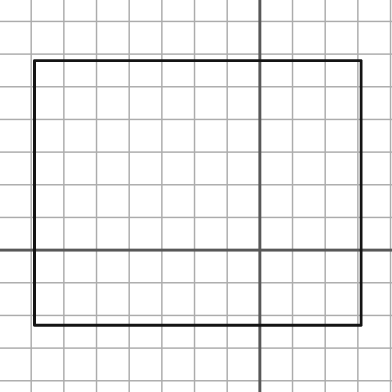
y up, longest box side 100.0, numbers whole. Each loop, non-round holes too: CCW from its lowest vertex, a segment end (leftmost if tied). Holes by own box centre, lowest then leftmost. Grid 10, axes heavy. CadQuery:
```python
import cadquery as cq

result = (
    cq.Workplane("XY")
    .moveTo(-69.0, -23.0)
    .lineTo(31.0, -23.0)
    .lineTo(31.0, 58.0)
    .lineTo(-69.0, 58.0)
    .close()
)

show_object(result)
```